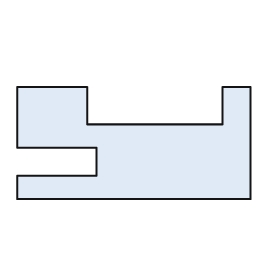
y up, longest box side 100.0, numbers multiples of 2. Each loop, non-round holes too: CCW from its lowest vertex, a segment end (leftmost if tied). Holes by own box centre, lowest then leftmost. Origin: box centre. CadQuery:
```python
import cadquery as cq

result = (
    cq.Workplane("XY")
    .moveTo(-50.0, -24.0)
    .lineTo(50.0, -24.0)
    .lineTo(50.0, 24.0)
    .lineTo(38.0, 24.0)
    .lineTo(38.0, 8.0)
    .lineTo(-20.0, 8.0)
    .lineTo(-20.0, 24.0)
    .lineTo(-50.0, 24.0)
    .lineTo(-50.0, -2.0)
    .lineTo(-16.0, -2.0)
    .lineTo(-16.0, -14.0)
    .lineTo(-50.0, -14.0)
    .close()
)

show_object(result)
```